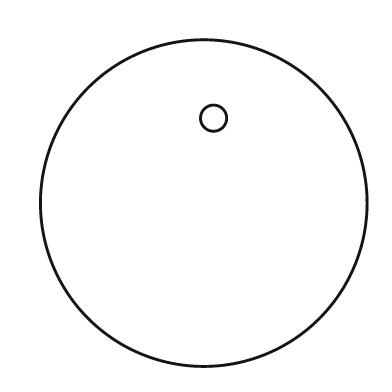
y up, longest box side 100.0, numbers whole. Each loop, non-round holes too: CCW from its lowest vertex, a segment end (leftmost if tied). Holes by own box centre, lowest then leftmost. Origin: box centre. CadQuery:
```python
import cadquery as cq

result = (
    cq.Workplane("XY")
    .moveTo(0.0, 0.0)
    .circle(50.0)
    .moveTo(3.0, 26.0)
    .circle(4.0)
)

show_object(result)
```